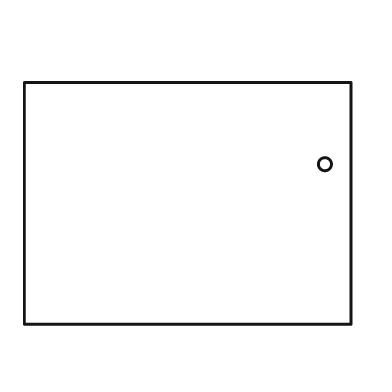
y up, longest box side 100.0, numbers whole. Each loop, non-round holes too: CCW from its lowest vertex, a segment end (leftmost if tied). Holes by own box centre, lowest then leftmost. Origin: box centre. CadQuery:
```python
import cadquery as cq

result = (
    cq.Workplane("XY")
    .moveTo(-50.0, -37.0)
    .lineTo(50.0, -37.0)
    .lineTo(50.0, 37.0)
    .lineTo(-50.0, 37.0)
    .close()
    .moveTo(42.0, 12.0)
    .circle(2.0)
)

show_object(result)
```